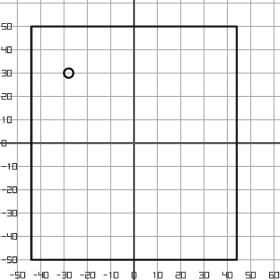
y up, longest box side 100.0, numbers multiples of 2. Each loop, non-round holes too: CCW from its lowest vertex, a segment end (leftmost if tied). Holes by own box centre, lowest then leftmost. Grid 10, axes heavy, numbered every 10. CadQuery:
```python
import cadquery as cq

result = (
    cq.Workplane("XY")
    .moveTo(-44.0, -50.0)
    .lineTo(44.0, -50.0)
    .lineTo(44.0, 50.0)
    .lineTo(-44.0, 50.0)
    .close()
    .moveTo(-28.0, 30.0)
    .circle(2.0)
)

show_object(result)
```